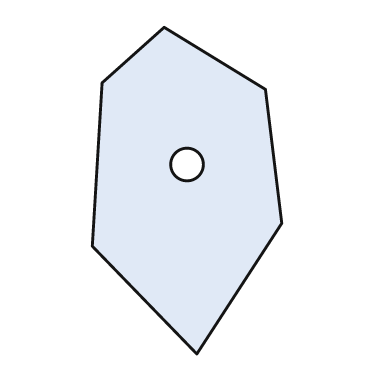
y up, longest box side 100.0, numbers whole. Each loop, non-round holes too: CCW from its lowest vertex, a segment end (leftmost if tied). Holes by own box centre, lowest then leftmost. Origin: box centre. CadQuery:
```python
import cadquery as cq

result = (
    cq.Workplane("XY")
    .moveTo(3.0, -50.0)
    .lineTo(29.0, -10.0)
    .lineTo(24.0, 31.0)
    .lineTo(-7.0, 50.0)
    .lineTo(-26.0, 33.0)
    .lineTo(-29.0, -17.0)
    .close()
    .moveTo(0.0, 8.0)
    .circle(5.0)
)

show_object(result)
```